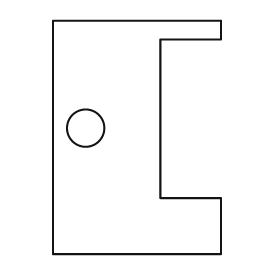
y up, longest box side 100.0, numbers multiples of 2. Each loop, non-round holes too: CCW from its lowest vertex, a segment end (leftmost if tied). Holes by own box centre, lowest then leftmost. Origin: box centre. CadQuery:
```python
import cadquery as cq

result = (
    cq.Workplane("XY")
    .moveTo(-36.0, -50.0)
    .lineTo(36.0, -50.0)
    .lineTo(36.0, -26.0)
    .lineTo(10.0, -26.0)
    .lineTo(10.0, 42.0)
    .lineTo(36.0, 42.0)
    .lineTo(36.0, 50.0)
    .lineTo(-36.0, 50.0)
    .close()
    .moveTo(-22.0, 4.0)
    .circle(8.0)
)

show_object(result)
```